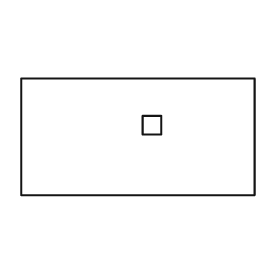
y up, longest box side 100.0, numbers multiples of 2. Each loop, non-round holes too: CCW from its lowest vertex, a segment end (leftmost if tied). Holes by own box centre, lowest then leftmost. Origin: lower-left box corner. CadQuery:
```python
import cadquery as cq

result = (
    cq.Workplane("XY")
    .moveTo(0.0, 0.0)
    .lineTo(100.0, 0.0)
    .lineTo(100.0, 50.0)
    .lineTo(0.0, 50.0)
    .close()
    .moveTo(52.0, 26.0)
    .lineTo(60.0, 26.0)
    .lineTo(60.0, 34.0)
    .lineTo(52.0, 34.0)
    .close()
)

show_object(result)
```